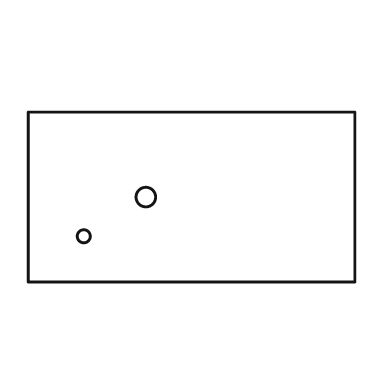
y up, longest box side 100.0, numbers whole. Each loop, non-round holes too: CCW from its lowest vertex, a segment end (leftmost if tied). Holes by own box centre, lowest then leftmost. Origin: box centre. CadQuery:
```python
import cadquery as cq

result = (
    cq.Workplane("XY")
    .moveTo(-50.0, -26.0)
    .lineTo(50.0, -26.0)
    .lineTo(50.0, 26.0)
    .lineTo(-50.0, 26.0)
    .close()
    .moveTo(-33.0, -12.0)
    .circle(2.0)
    .moveTo(-14.0, 0.0)
    .circle(3.0)
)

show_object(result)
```